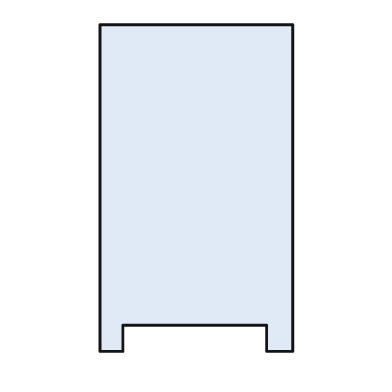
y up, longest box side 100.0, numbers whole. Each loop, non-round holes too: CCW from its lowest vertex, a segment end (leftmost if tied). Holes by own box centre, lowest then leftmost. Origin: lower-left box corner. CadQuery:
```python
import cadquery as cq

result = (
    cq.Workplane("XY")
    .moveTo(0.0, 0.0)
    .lineTo(7.0, 0.0)
    .lineTo(7.0, 8.0)
    .lineTo(51.0, 8.0)
    .lineTo(51.0, 0.0)
    .lineTo(59.0, 0.0)
    .lineTo(59.0, 100.0)
    .lineTo(0.0, 100.0)
    .close()
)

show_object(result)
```